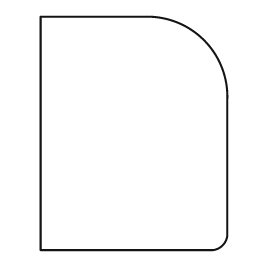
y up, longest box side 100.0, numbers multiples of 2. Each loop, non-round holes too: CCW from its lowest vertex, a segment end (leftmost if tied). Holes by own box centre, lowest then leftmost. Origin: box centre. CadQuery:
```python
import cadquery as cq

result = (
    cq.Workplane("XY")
    .moveTo(-40.0, -50.0)
    .lineTo(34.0, -50.0)
    .threePointArc((38.0, -48.0), (40.0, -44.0))
    .lineTo(40.0, 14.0)
    .threePointArc((30.0, 40.0), (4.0, 50.0))
    .lineTo(-40.0, 50.0)
    .close()
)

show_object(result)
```